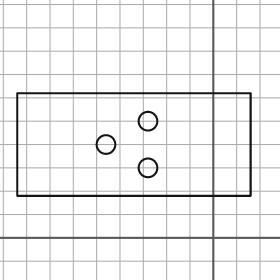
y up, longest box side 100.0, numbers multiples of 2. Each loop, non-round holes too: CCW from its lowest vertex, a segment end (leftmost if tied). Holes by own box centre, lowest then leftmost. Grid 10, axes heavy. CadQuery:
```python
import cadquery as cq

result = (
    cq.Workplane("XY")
    .moveTo(-84.0, 18.0)
    .lineTo(16.0, 18.0)
    .lineTo(16.0, 62.0)
    .lineTo(-84.0, 62.0)
    .close()
    .moveTo(-28.0, 30.0)
    .circle(4.0)
    .moveTo(-46.0, 40.0)
    .circle(4.0)
    .moveTo(-28.0, 50.0)
    .circle(4.0)
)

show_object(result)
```